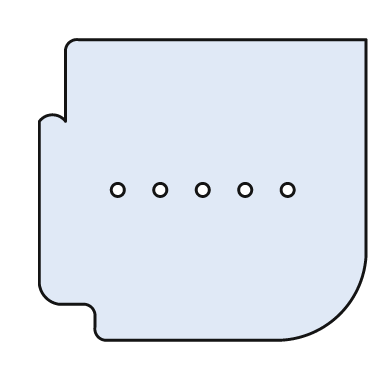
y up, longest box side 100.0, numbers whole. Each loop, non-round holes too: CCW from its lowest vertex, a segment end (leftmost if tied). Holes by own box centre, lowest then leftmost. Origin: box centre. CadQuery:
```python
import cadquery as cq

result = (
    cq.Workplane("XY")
    .moveTo(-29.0, -46.0)
    .lineTo(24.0, -46.0)
    .threePointArc((42.0, -38.0), (50.0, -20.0))
    .lineTo(50.0, 46.0)
    .lineTo(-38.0, 46.0)
    .threePointArc((-41.0, 45.0), (-42.0, 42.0))
    .lineTo(-42.0, 21.0)
    .threePointArc((-46.0, 23.0), (-50.0, 21.0))
    .lineTo(-50.0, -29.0)
    .threePointArc((-48.0, -33.0), (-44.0, -35.0))
    .lineTo(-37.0, -35.0)
    .threePointArc((-34.0, -36.0), (-33.0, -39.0))
    .lineTo(-33.0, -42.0)
    .threePointArc((-32.0, -45.0), (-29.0, -46.0))
    .close()
    .moveTo(-26.0, 0.0)
    .circle(2.0)
    .moveTo(-13.0, 0.0)
    .circle(2.0)
    .moveTo(0.0, 0.0)
    .circle(2.0)
    .moveTo(13.0, 0.0)
    .circle(2.0)
    .moveTo(26.0, 0.0)
    .circle(2.0)
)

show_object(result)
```